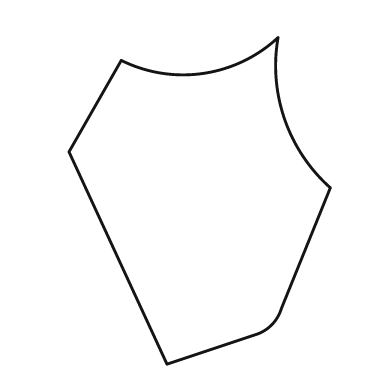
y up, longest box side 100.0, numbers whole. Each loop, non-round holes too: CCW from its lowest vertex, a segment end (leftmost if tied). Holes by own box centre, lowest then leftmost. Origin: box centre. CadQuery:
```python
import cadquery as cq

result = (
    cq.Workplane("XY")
    .moveTo(-10.0, -50.0)
    .lineTo(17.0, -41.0)
    .threePointArc((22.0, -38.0), (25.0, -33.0))
    .lineTo(40.0, 4.0)
    .threePointArc((26.0, 25.0), (24.0, 50.0))
    .threePointArc((1.0, 39.0), (-24.0, 43.0))
    .lineTo(-40.0, 15.0)
    .close()
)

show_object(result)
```